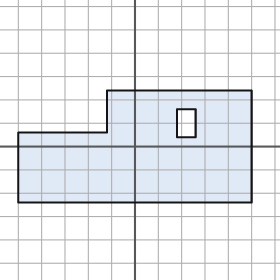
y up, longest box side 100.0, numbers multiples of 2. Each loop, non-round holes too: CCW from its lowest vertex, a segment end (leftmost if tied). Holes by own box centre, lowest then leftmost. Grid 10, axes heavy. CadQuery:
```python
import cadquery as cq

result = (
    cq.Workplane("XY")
    .moveTo(-50.0, -24.0)
    .lineTo(50.0, -24.0)
    .lineTo(50.0, 24.0)
    .lineTo(-12.0, 24.0)
    .lineTo(-12.0, 6.0)
    .lineTo(-50.0, 6.0)
    .close()
    .moveTo(18.0, 4.0)
    .lineTo(26.0, 4.0)
    .lineTo(26.0, 16.0)
    .lineTo(18.0, 16.0)
    .close()
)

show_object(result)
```